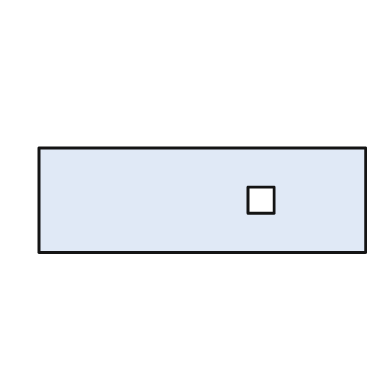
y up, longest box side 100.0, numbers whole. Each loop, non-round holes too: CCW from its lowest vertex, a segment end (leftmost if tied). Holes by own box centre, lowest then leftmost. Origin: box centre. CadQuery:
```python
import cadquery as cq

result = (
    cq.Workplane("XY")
    .moveTo(-50.0, -16.0)
    .lineTo(50.0, -16.0)
    .lineTo(50.0, 16.0)
    .lineTo(-50.0, 16.0)
    .close()
    .moveTo(14.0, -4.0)
    .lineTo(22.0, -4.0)
    .lineTo(22.0, 4.0)
    .lineTo(14.0, 4.0)
    .close()
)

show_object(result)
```